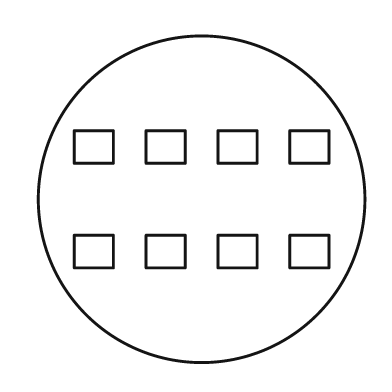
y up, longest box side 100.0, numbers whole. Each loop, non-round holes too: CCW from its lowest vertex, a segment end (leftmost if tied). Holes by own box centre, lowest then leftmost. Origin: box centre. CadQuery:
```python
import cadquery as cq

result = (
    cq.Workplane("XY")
    .moveTo(0.0, 0.0)
    .circle(50.0)
    .moveTo(-39.0, -21.0)
    .lineTo(-27.0, -21.0)
    .lineTo(-27.0, -11.0)
    .lineTo(-39.0, -11.0)
    .close()
    .moveTo(-17.0, -21.0)
    .lineTo(-5.0, -21.0)
    .lineTo(-5.0, -11.0)
    .lineTo(-17.0, -11.0)
    .close()
    .moveTo(5.0, -21.0)
    .lineTo(17.0, -21.0)
    .lineTo(17.0, -11.0)
    .lineTo(5.0, -11.0)
    .close()
    .moveTo(27.0, -21.0)
    .lineTo(39.0, -21.0)
    .lineTo(39.0, -11.0)
    .lineTo(27.0, -11.0)
    .close()
    .moveTo(-39.0, 11.0)
    .lineTo(-27.0, 11.0)
    .lineTo(-27.0, 21.0)
    .lineTo(-39.0, 21.0)
    .close()
    .moveTo(-17.0, 11.0)
    .lineTo(-5.0, 11.0)
    .lineTo(-5.0, 21.0)
    .lineTo(-17.0, 21.0)
    .close()
    .moveTo(5.0, 11.0)
    .lineTo(17.0, 11.0)
    .lineTo(17.0, 21.0)
    .lineTo(5.0, 21.0)
    .close()
    .moveTo(27.0, 11.0)
    .lineTo(39.0, 11.0)
    .lineTo(39.0, 21.0)
    .lineTo(27.0, 21.0)
    .close()
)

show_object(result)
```